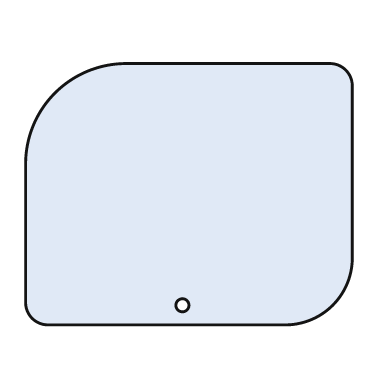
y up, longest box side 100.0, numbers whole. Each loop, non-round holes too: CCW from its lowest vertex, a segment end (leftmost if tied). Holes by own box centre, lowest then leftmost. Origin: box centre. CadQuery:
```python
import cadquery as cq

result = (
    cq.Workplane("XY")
    .moveTo(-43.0, -40.0)
    .lineTo(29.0, -40.0)
    .threePointArc((44.0, -34.0), (50.0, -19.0))
    .lineTo(50.0, 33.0)
    .threePointArc((48.0, 38.0), (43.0, 40.0))
    .lineTo(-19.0, 40.0)
    .threePointArc((-41.0, 31.0), (-50.0, 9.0))
    .lineTo(-50.0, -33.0)
    .threePointArc((-48.0, -38.0), (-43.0, -40.0))
    .close()
    .moveTo(-2.0, -34.0)
    .circle(2.0)
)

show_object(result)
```